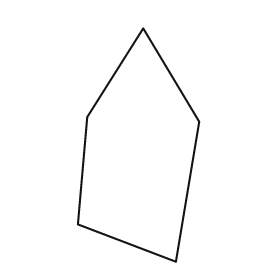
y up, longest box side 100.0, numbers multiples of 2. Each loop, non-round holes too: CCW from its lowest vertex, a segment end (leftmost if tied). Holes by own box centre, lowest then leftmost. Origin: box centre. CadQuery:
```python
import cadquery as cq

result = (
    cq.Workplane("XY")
    .moveTo(16.0, -50.0)
    .lineTo(26.0, 10.0)
    .lineTo(2.0, 50.0)
    .lineTo(-22.0, 12.0)
    .lineTo(-26.0, -34.0)
    .close()
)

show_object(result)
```